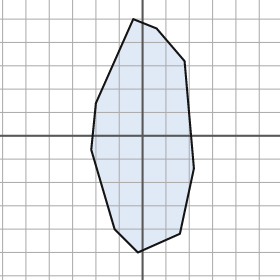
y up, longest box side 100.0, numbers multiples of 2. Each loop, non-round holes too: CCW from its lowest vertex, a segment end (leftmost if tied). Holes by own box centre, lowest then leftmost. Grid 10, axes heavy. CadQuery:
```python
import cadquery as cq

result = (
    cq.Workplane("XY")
    .moveTo(-2.0, -50.0)
    .lineTo(16.0, -42.0)
    .lineTo(22.0, -14.0)
    .lineTo(18.0, 32.0)
    .lineTo(6.0, 46.0)
    .lineTo(-4.0, 50.0)
    .lineTo(-20.0, 14.0)
    .lineTo(-22.0, -6.0)
    .lineTo(-12.0, -40.0)
    .close()
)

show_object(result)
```